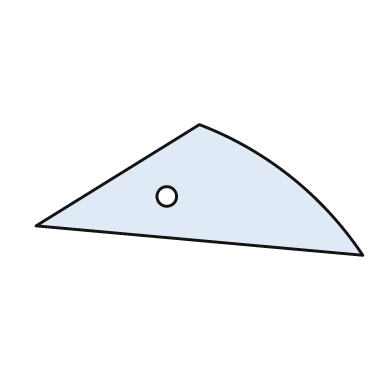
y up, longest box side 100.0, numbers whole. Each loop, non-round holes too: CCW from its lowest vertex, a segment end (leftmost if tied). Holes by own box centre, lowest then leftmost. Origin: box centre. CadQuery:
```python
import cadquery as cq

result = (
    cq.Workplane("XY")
    .moveTo(50.0, -20.0)
    .threePointArc((28.0, 4.0), (0.0, 20.0))
    .lineTo(-50.0, -11.0)
    .close()
    .moveTo(-10.0, -2.0)
    .circle(3.0)
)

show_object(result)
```